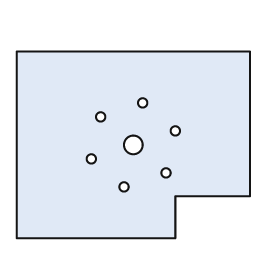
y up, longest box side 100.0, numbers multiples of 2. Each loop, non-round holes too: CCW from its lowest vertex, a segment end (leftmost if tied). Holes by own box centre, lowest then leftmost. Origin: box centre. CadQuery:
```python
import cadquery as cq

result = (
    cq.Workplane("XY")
    .moveTo(-50.0, -40.0)
    .lineTo(18.0, -40.0)
    .lineTo(18.0, -22.0)
    .lineTo(50.0, -22.0)
    .lineTo(50.0, 40.0)
    .lineTo(-50.0, 40.0)
    .close()
    .moveTo(-4.0, -18.0)
    .circle(2.0)
    .moveTo(14.0, -12.0)
    .circle(2.0)
    .moveTo(-18.0, -6.0)
    .circle(2.0)
    .moveTo(0.0, 0.0)
    .circle(4.0)
    .moveTo(18.0, 6.0)
    .circle(2.0)
    .moveTo(-14.0, 12.0)
    .circle(2.0)
    .moveTo(4.0, 18.0)
    .circle(2.0)
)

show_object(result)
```